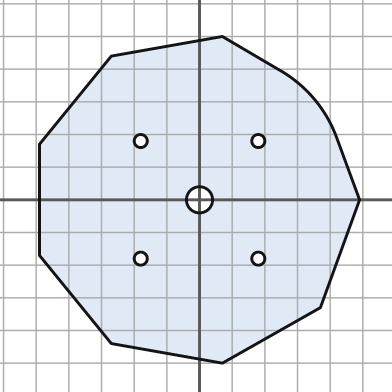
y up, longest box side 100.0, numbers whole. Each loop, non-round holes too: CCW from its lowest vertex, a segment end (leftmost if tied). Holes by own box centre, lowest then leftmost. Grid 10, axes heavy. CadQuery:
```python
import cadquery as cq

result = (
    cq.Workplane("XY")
    .moveTo(7.0, -50.0)
    .lineTo(37.0, -33.0)
    .lineTo(49.0, 0.0)
    .lineTo(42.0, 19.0)
    .threePointArc((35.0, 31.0), (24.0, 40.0))
    .lineTo(7.0, 50.0)
    .lineTo(-27.0, 44.0)
    .lineTo(-49.0, 17.0)
    .lineTo(-49.0, -17.0)
    .lineTo(-27.0, -44.0)
    .close()
    .moveTo(-18.0, -18.0)
    .circle(2.0)
    .moveTo(18.0, -18.0)
    .circle(2.0)
    .moveTo(0.0, 0.0)
    .circle(4.0)
    .moveTo(-18.0, 18.0)
    .circle(2.0)
    .moveTo(18.0, 18.0)
    .circle(2.0)
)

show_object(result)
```